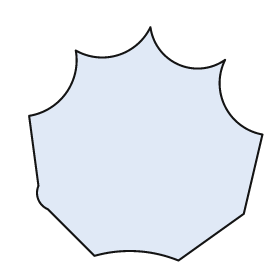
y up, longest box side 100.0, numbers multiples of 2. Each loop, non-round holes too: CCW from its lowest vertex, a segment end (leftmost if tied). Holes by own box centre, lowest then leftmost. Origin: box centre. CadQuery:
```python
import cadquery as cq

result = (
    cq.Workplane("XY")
    .moveTo(14.0, -50.0)
    .lineTo(42.0, -30.0)
    .lineTo(50.0, 4.0)
    .threePointArc((34.0, 16.0), (34.0, 36.0))
    .threePointArc((14.0, 34.0), (2.0, 50.0))
    .threePointArc((-12.0, 38.0), (-30.0, 40.0))
    .threePointArc((-34.0, 22.0), (-50.0, 12.0))
    .lineTo(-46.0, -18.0)
    .threePointArc((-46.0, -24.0), (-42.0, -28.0))
    .lineTo(-22.0, -48.0)
    .threePointArc((-4.0, -46.0), (14.0, -50.0))
    .close()
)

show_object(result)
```